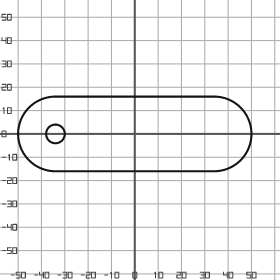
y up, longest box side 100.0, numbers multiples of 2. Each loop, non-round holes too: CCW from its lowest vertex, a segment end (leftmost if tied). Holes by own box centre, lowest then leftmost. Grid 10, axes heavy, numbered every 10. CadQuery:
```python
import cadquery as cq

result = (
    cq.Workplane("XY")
    .moveTo(-34.0, -16.0)
    .lineTo(34.0, -16.0)
    .threePointArc((50.0, 0.0), (34.0, 16.0))
    .lineTo(-34.0, 16.0)
    .threePointArc((-50.0, 0.0), (-34.0, -16.0))
    .close()
    .moveTo(-34.0, 0.0)
    .circle(4.0)
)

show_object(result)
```